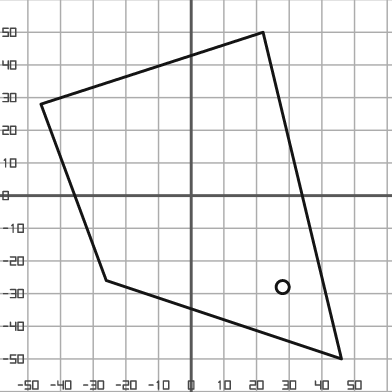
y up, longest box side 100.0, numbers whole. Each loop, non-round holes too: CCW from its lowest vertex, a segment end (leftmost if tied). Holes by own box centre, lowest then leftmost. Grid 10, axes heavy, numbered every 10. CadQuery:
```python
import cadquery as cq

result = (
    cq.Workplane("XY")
    .moveTo(46.0, -50.0)
    .lineTo(22.0, 50.0)
    .lineTo(-46.0, 28.0)
    .lineTo(-26.0, -26.0)
    .close()
    .moveTo(28.0, -28.0)
    .circle(2.0)
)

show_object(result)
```